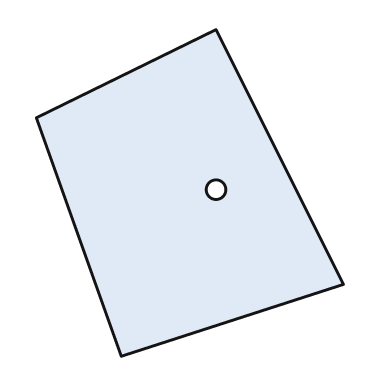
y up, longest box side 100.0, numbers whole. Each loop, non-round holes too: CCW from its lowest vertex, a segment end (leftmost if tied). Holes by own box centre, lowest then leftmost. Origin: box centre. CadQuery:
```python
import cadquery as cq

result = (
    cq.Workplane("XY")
    .moveTo(-21.0, -50.0)
    .lineTo(47.0, -28.0)
    .lineTo(8.0, 50.0)
    .lineTo(-47.0, 23.0)
    .close()
    .moveTo(8.0, 1.0)
    .circle(3.0)
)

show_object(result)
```